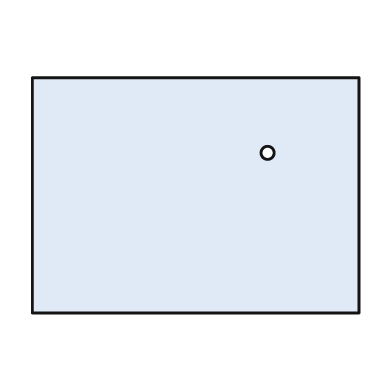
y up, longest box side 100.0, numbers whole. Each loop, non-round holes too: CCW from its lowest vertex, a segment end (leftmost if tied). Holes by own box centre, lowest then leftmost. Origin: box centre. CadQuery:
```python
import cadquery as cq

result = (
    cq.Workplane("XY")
    .moveTo(-50.0, -36.0)
    .lineTo(50.0, -36.0)
    .lineTo(50.0, 36.0)
    .lineTo(-50.0, 36.0)
    .close()
    .moveTo(22.0, 13.0)
    .circle(2.0)
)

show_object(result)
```